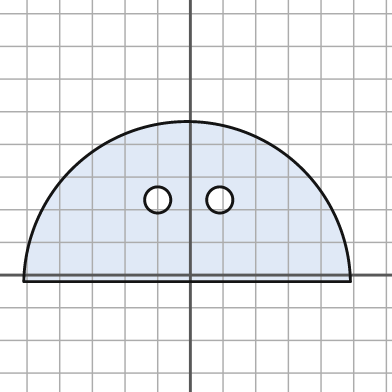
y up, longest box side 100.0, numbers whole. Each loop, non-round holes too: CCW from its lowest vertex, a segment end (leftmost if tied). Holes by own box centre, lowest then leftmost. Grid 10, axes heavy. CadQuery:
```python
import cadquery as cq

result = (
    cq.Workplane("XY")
    .moveTo(-51.0, -2.0)
    .lineTo(49.0, -2.0)
    .threePointArc((-1.0, 47.0), (-51.0, -2.0))
    .close()
    .moveTo(-10.0, 23.0)
    .circle(4.0)
    .moveTo(9.0, 23.0)
    .circle(4.0)
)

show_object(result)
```